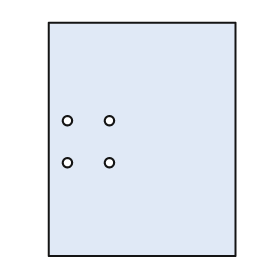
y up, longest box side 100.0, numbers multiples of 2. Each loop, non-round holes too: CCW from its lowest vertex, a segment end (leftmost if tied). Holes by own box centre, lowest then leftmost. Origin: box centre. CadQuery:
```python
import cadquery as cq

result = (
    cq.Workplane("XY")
    .moveTo(-40.0, -50.0)
    .lineTo(40.0, -50.0)
    .lineTo(40.0, 50.0)
    .lineTo(-40.0, 50.0)
    .close()
    .moveTo(-32.0, -10.0)
    .circle(2.0)
    .moveTo(-14.0, -10.0)
    .circle(2.0)
    .moveTo(-32.0, 8.0)
    .circle(2.0)
    .moveTo(-14.0, 8.0)
    .circle(2.0)
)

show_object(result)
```